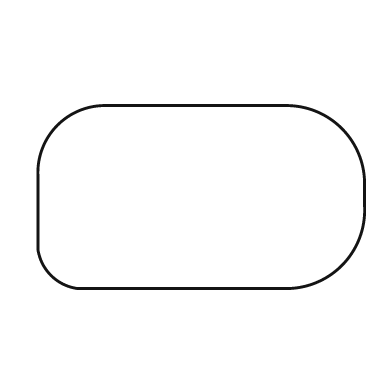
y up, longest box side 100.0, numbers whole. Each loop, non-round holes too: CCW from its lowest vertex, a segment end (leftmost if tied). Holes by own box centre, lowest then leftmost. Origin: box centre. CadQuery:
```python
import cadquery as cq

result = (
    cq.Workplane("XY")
    .moveTo(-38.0, -28.0)
    .lineTo(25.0, -28.0)
    .threePointArc((43.0, -21.0), (50.0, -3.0))
    .lineTo(50.0, 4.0)
    .threePointArc((43.0, 21.0), (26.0, 28.0))
    .lineTo(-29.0, 28.0)
    .threePointArc((-44.0, 22.0), (-50.0, 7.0))
    .lineTo(-50.0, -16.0)
    .threePointArc((-46.0, -24.0), (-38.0, -28.0))
    .close()
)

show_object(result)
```